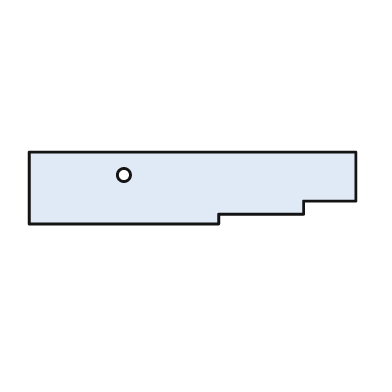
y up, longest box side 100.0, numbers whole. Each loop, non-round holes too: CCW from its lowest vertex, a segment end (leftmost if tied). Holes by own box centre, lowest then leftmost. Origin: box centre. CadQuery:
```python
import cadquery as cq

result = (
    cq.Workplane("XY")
    .moveTo(-50.0, -11.0)
    .lineTo(8.0, -11.0)
    .lineTo(8.0, -8.0)
    .lineTo(34.0, -8.0)
    .lineTo(34.0, -4.0)
    .lineTo(50.0, -4.0)
    .lineTo(50.0, 11.0)
    .lineTo(-50.0, 11.0)
    .close()
    .moveTo(-21.0, 4.0)
    .circle(2.0)
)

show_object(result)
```